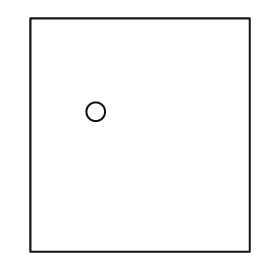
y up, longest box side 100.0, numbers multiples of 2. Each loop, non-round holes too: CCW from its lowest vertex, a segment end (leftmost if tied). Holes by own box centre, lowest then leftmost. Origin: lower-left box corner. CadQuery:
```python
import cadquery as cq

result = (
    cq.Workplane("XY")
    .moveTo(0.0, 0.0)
    .lineTo(94.0, 0.0)
    .lineTo(94.0, 100.0)
    .lineTo(0.0, 100.0)
    .close()
    .moveTo(28.0, 60.0)
    .circle(4.0)
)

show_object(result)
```